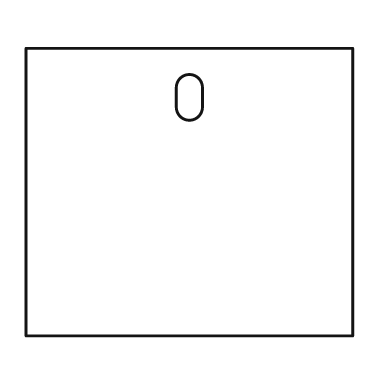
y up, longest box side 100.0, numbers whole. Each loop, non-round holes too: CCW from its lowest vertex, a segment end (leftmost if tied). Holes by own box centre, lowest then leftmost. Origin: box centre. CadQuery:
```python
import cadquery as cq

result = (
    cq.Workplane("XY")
    .moveTo(-50.0, -44.0)
    .lineTo(50.0, -44.0)
    .lineTo(50.0, 44.0)
    .lineTo(-50.0, 44.0)
    .close()
    .moveTo(-4.0, 26.0)
    .threePointArc((0.0, 22.0), (4.0, 26.0))
    .lineTo(4.0, 32.0)
    .threePointArc((0.0, 36.0), (-4.0, 32.0))
    .close()
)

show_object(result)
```